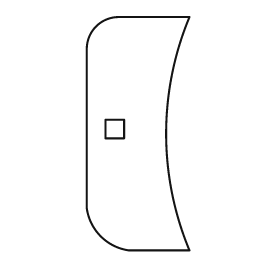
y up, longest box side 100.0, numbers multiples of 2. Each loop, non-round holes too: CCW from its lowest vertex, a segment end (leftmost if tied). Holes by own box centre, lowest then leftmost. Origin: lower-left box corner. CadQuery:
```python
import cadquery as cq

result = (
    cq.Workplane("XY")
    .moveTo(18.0, 0.0)
    .lineTo(44.0, 0.0)
    .threePointArc((34.0, 50.0), (44.0, 100.0))
    .lineTo(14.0, 100.0)
    .threePointArc((4.0, 96.0), (0.0, 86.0))
    .lineTo(0.0, 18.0)
    .threePointArc((6.0, 6.0), (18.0, 0.0))
    .close()
    .moveTo(8.0, 48.0)
    .lineTo(16.0, 48.0)
    .lineTo(16.0, 56.0)
    .lineTo(8.0, 56.0)
    .close()
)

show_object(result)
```